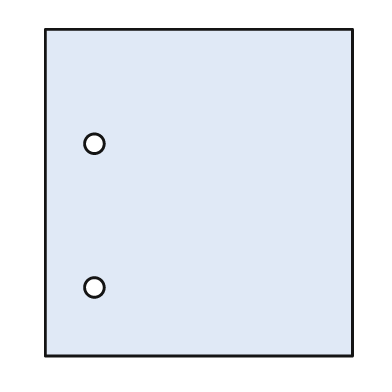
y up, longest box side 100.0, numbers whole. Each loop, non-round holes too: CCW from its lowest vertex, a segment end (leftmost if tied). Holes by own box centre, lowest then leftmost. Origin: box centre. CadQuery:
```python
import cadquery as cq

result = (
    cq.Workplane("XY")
    .moveTo(-47.0, -50.0)
    .lineTo(47.0, -50.0)
    .lineTo(47.0, 50.0)
    .lineTo(-47.0, 50.0)
    .close()
    .moveTo(-32.0, -29.0)
    .circle(3.0)
    .moveTo(-32.0, 15.0)
    .circle(3.0)
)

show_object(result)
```